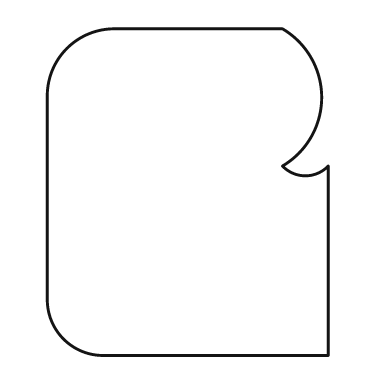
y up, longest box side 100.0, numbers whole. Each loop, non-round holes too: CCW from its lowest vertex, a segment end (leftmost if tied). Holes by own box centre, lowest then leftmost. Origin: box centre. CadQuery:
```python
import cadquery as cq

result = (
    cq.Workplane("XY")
    .moveTo(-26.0, -50.0)
    .lineTo(43.0, -50.0)
    .lineTo(43.0, 8.0)
    .threePointArc((36.0, 5.0), (29.0, 8.0))
    .threePointArc((41.0, 29.0), (29.0, 50.0))
    .lineTo(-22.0, 50.0)
    .threePointArc((-37.0, 44.0), (-43.0, 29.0))
    .lineTo(-43.0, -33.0)
    .threePointArc((-38.0, -45.0), (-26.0, -50.0))
    .close()
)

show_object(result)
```